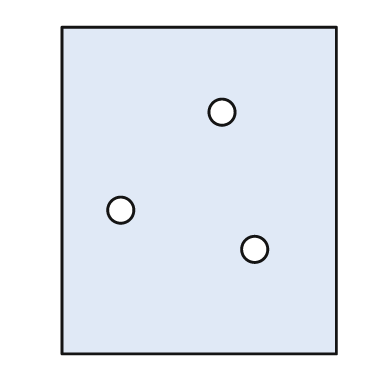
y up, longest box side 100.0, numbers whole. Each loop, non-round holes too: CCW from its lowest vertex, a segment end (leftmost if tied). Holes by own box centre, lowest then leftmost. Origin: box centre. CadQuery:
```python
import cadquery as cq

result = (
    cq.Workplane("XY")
    .moveTo(-42.0, -50.0)
    .lineTo(42.0, -50.0)
    .lineTo(42.0, 50.0)
    .lineTo(-42.0, 50.0)
    .close()
    .moveTo(17.0, -18.0)
    .circle(4.0)
    .moveTo(-24.0, -6.0)
    .circle(4.0)
    .moveTo(7.0, 24.0)
    .circle(4.0)
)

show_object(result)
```